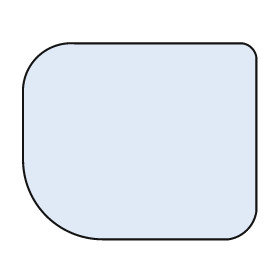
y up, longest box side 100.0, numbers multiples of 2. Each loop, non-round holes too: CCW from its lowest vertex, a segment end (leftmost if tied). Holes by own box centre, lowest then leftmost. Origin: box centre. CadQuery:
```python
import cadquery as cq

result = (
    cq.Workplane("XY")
    .moveTo(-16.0, -42.0)
    .lineTo(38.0, -42.0)
    .threePointArc((46.0, -38.0), (50.0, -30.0))
    .lineTo(50.0, 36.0)
    .threePointArc((48.0, 40.0), (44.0, 42.0))
    .lineTo(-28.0, 42.0)
    .threePointArc((-44.0, 36.0), (-50.0, 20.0))
    .lineTo(-50.0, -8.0)
    .threePointArc((-40.0, -32.0), (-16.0, -42.0))
    .close()
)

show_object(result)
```